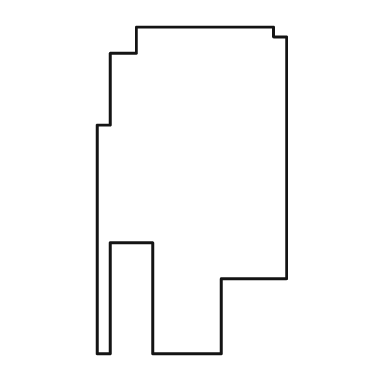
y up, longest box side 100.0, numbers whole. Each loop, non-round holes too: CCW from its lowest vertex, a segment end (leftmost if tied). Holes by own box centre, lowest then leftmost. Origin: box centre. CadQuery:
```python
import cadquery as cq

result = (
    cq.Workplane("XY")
    .moveTo(-29.0, -50.0)
    .lineTo(-25.0, -50.0)
    .lineTo(-25.0, -16.0)
    .lineTo(-12.0, -16.0)
    .lineTo(-12.0, -50.0)
    .lineTo(9.0, -50.0)
    .lineTo(9.0, -27.0)
    .lineTo(29.0, -27.0)
    .lineTo(29.0, 47.0)
    .lineTo(25.0, 47.0)
    .lineTo(25.0, 50.0)
    .lineTo(-17.0, 50.0)
    .lineTo(-17.0, 42.0)
    .lineTo(-25.0, 42.0)
    .lineTo(-25.0, 20.0)
    .lineTo(-29.0, 20.0)
    .close()
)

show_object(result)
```